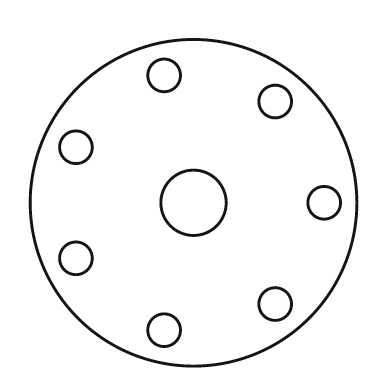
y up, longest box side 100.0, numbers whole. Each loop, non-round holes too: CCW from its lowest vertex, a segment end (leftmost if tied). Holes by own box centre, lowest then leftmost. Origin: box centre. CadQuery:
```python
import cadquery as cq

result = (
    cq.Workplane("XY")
    .moveTo(0.0, 0.0)
    .circle(50.0)
    .moveTo(-9.0, -39.0)
    .circle(5.0)
    .moveTo(25.0, -31.0)
    .circle(5.0)
    .moveTo(-36.0, -17.0)
    .circle(5.0)
    .moveTo(0.0, 0.0)
    .circle(10.0)
    .moveTo(40.0, 0.0)
    .circle(5.0)
    .moveTo(-36.0, 17.0)
    .circle(5.0)
    .moveTo(25.0, 31.0)
    .circle(5.0)
    .moveTo(-9.0, 39.0)
    .circle(5.0)
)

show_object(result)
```